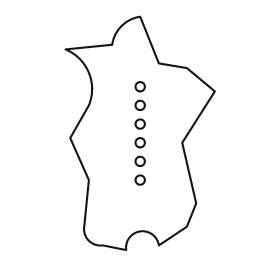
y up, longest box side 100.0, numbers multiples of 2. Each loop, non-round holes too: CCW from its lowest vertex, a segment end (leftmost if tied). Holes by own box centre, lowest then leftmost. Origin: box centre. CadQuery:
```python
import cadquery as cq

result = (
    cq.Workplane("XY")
    .moveTo(-6.0, -50.0)
    .threePointArc((0.0, -42.0), (8.0, -48.0))
    .lineTo(20.0, -40.0)
    .lineTo(24.0, -30.0)
    .lineTo(18.0, -4.0)
    .lineTo(32.0, 18.0)
    .lineTo(20.0, 28.0)
    .lineTo(8.0, 30.0)
    .lineTo(0.0, 50.0)
    .threePointArc((-8.0, 46.0), (-12.0, 38.0))
    .lineTo(-32.0, 36.0)
    .threePointArc((-22.0, 26.0), (-22.0, 12.0))
    .lineTo(-30.0, -2.0)
    .lineTo(-22.0, -20.0)
    .lineTo(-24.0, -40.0)
    .threePointArc((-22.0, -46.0), (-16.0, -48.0))
    .close()
    .moveTo(0.0, -20.0)
    .circle(2.0)
    .moveTo(0.0, -12.0)
    .circle(2.0)
    .moveTo(0.0, -4.0)
    .circle(2.0)
    .moveTo(0.0, 4.0)
    .circle(2.0)
    .moveTo(0.0, 12.0)
    .circle(2.0)
    .moveTo(0.0, 20.0)
    .circle(2.0)
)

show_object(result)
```